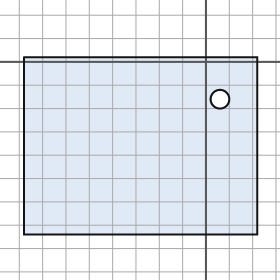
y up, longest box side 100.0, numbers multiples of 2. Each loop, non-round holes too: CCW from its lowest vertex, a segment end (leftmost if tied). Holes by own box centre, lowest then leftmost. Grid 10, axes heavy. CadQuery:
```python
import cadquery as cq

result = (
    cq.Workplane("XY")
    .moveTo(-78.0, -74.0)
    .lineTo(22.0, -74.0)
    .lineTo(22.0, 2.0)
    .lineTo(-78.0, 2.0)
    .close()
    .moveTo(6.0, -16.0)
    .circle(4.0)
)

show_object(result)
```